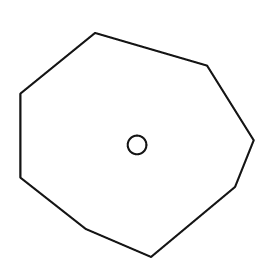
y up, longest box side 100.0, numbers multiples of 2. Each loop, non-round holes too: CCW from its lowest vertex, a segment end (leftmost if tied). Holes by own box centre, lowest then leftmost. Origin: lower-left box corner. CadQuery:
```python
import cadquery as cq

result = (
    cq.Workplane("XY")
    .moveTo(56.0, 0.0)
    .lineTo(92.0, 30.0)
    .lineTo(100.0, 50.0)
    .lineTo(80.0, 82.0)
    .lineTo(32.0, 96.0)
    .lineTo(0.0, 70.0)
    .lineTo(0.0, 34.0)
    .lineTo(28.0, 12.0)
    .close()
    .moveTo(50.0, 48.0)
    .circle(4.0)
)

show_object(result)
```